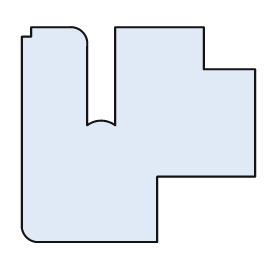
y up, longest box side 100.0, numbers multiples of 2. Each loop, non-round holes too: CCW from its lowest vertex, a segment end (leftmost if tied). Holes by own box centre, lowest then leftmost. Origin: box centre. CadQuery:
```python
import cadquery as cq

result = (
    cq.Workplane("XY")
    .moveTo(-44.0, -46.0)
    .lineTo(8.0, -46.0)
    .lineTo(8.0, -18.0)
    .lineTo(50.0, -18.0)
    .lineTo(50.0, 28.0)
    .lineTo(28.0, 28.0)
    .lineTo(28.0, 46.0)
    .lineTo(-10.0, 46.0)
    .lineTo(-10.0, 4.0)
    .threePointArc((-16.0, 6.0), (-22.0, 4.0))
    .lineTo(-22.0, 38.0)
    .threePointArc((-24.0, 44.0), (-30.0, 46.0))
    .lineTo(-46.0, 46.0)
    .lineTo(-46.0, 42.0)
    .lineTo(-50.0, 42.0)
    .lineTo(-50.0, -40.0)
    .threePointArc((-48.0, -44.0), (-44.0, -46.0))
    .close()
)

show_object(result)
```